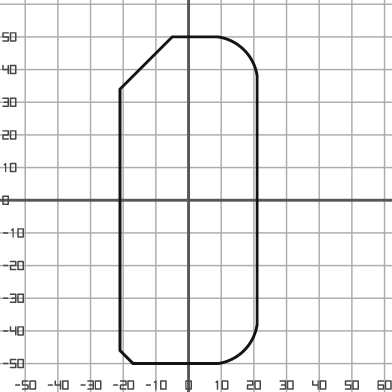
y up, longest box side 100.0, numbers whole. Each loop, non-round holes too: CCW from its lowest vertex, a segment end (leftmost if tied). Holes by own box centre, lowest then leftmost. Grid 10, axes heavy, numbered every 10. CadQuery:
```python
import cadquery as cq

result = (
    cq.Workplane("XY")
    .moveTo(-17.0, -50.0)
    .lineTo(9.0, -50.0)
    .threePointArc((17.0, -46.0), (21.0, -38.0))
    .lineTo(21.0, 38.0)
    .threePointArc((17.0, 46.0), (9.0, 50.0))
    .lineTo(-5.0, 50.0)
    .lineTo(-21.0, 34.0)
    .lineTo(-21.0, -46.0)
    .close()
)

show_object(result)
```